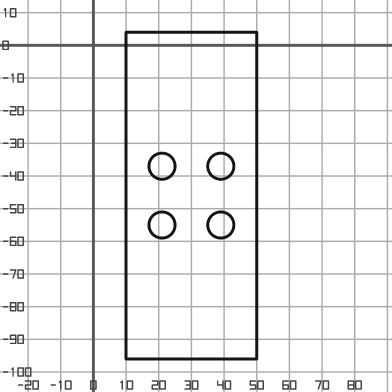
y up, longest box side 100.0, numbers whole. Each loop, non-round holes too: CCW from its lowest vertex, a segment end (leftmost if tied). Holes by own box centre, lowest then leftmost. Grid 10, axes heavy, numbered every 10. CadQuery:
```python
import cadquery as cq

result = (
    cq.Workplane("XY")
    .moveTo(10.0, -96.0)
    .lineTo(50.0, -96.0)
    .lineTo(50.0, 4.0)
    .lineTo(10.0, 4.0)
    .close()
    .moveTo(21.0, -55.0)
    .circle(4.0)
    .moveTo(39.0, -55.0)
    .circle(4.0)
    .moveTo(21.0, -37.0)
    .circle(4.0)
    .moveTo(39.0, -37.0)
    .circle(4.0)
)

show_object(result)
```